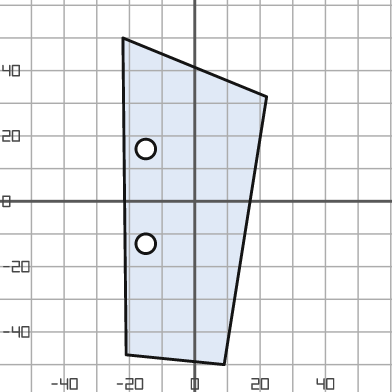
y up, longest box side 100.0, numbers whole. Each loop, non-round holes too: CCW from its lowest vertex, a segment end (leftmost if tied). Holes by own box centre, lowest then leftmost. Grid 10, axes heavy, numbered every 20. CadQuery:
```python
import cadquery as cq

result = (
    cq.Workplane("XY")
    .moveTo(9.0, -50.0)
    .lineTo(22.0, 32.0)
    .lineTo(-22.0, 50.0)
    .lineTo(-21.0, -47.0)
    .close()
    .moveTo(-15.0, -13.0)
    .circle(3.0)
    .moveTo(-15.0, 16.0)
    .circle(3.0)
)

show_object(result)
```